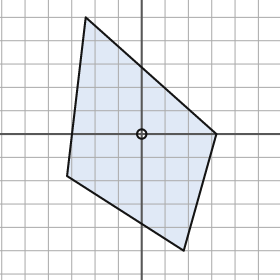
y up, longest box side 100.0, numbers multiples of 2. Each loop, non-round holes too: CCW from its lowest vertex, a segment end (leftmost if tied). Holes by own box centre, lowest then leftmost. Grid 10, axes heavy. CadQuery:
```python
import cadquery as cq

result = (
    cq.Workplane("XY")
    .moveTo(18.0, -50.0)
    .lineTo(32.0, 0.0)
    .lineTo(-24.0, 50.0)
    .lineTo(-32.0, -18.0)
    .close()
    .moveTo(0.0, 0.0)
    .circle(2.0)
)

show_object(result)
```